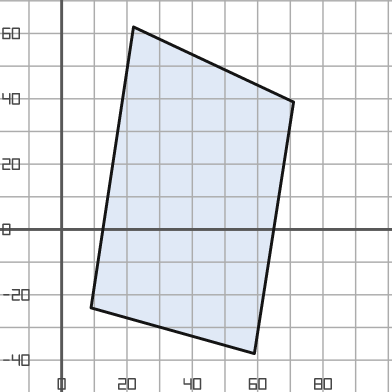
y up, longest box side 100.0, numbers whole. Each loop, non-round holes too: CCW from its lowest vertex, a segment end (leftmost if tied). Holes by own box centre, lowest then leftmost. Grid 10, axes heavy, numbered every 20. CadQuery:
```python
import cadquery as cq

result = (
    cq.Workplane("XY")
    .moveTo(59.0, -38.0)
    .lineTo(71.0, 39.0)
    .lineTo(22.0, 62.0)
    .lineTo(9.0, -24.0)
    .close()
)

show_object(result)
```